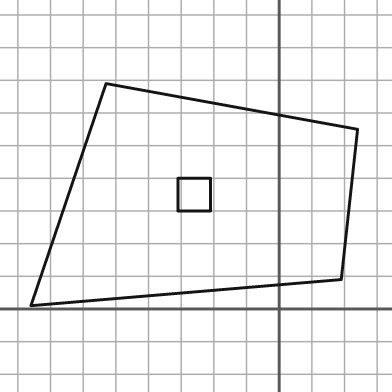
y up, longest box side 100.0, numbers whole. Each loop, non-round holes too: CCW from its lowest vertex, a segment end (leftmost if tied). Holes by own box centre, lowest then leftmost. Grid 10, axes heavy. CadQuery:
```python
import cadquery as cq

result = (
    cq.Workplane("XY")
    .moveTo(-76.0, 1.0)
    .lineTo(19.0, 9.0)
    .lineTo(24.0, 55.0)
    .lineTo(-53.0, 69.0)
    .close()
    .moveTo(-31.0, 30.0)
    .lineTo(-21.0, 30.0)
    .lineTo(-21.0, 40.0)
    .lineTo(-31.0, 40.0)
    .close()
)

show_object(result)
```